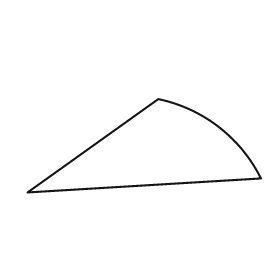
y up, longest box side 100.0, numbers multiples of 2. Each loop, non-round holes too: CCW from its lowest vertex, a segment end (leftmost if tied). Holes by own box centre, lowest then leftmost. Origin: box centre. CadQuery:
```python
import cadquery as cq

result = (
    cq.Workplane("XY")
    .moveTo(-50.0, -20.0)
    .lineTo(50.0, -14.0)
    .threePointArc((32.0, 8.0), (6.0, 20.0))
    .close()
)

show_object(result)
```